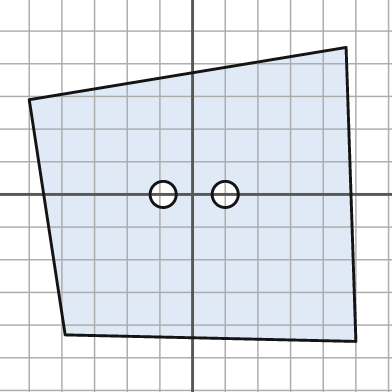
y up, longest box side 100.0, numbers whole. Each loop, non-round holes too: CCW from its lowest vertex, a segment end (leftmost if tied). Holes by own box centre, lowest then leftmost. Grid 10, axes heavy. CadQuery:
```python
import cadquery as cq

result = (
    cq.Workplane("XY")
    .moveTo(50.0, -45.0)
    .lineTo(47.0, 45.0)
    .lineTo(-50.0, 29.0)
    .lineTo(-39.0, -43.0)
    .close()
    .moveTo(-9.0, 0.0)
    .circle(4.0)
    .moveTo(10.0, 0.0)
    .circle(4.0)
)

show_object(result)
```